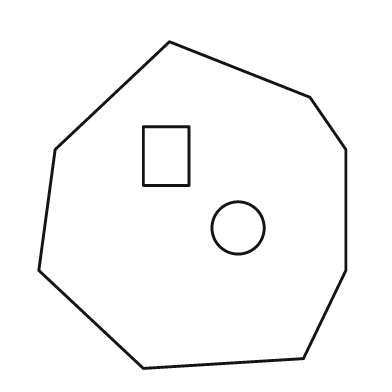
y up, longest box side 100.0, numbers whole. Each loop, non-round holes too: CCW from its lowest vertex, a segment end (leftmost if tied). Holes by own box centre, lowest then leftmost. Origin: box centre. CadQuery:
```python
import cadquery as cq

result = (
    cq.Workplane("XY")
    .moveTo(-15.0, -50.0)
    .lineTo(34.0, -47.0)
    .lineTo(47.0, -20.0)
    .lineTo(47.0, 17.0)
    .lineTo(36.0, 33.0)
    .lineTo(-7.0, 50.0)
    .lineTo(-42.0, 17.0)
    .lineTo(-47.0, -20.0)
    .close()
    .moveTo(14.0, -7.0)
    .circle(8.0)
    .moveTo(-15.0, 6.0)
    .lineTo(-1.0, 6.0)
    .lineTo(-1.0, 24.0)
    .lineTo(-15.0, 24.0)
    .close()
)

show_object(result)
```